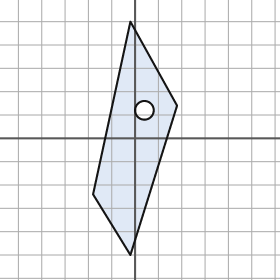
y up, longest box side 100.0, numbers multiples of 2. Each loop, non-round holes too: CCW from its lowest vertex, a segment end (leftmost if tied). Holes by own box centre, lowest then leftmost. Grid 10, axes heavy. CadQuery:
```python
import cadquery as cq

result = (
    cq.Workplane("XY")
    .moveTo(-2.0, -50.0)
    .lineTo(18.0, 14.0)
    .lineTo(-2.0, 50.0)
    .lineTo(-18.0, -24.0)
    .close()
    .moveTo(4.0, 12.0)
    .circle(4.0)
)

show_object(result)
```